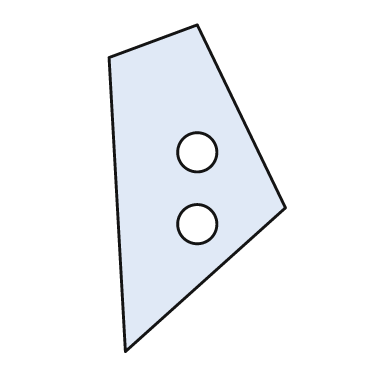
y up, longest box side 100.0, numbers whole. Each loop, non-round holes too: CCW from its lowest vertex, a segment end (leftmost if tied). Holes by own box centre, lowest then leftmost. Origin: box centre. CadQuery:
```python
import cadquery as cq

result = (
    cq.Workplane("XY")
    .moveTo(-22.0, -50.0)
    .lineTo(27.0, -6.0)
    .lineTo(0.0, 50.0)
    .lineTo(-27.0, 40.0)
    .close()
    .moveTo(0.0, -11.0)
    .circle(6.0)
    .moveTo(0.0, 11.0)
    .circle(6.0)
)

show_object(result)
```